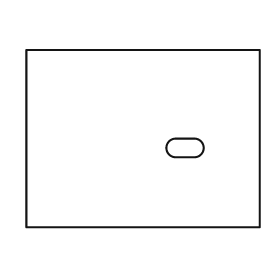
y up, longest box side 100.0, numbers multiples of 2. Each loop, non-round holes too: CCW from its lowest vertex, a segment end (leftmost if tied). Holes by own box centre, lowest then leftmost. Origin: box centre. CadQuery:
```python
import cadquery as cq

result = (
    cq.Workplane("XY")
    .moveTo(-50.0, -38.0)
    .lineTo(50.0, -38.0)
    .lineTo(50.0, 38.0)
    .lineTo(-50.0, 38.0)
    .close()
    .moveTo(14.0, -8.0)
    .lineTo(22.0, -8.0)
    .threePointArc((26.0, -4.0), (22.0, 0.0))
    .lineTo(14.0, 0.0)
    .threePointArc((10.0, -4.0), (14.0, -8.0))
    .close()
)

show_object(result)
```